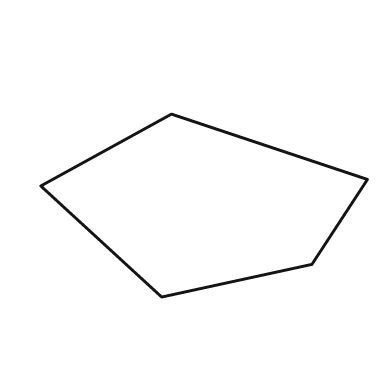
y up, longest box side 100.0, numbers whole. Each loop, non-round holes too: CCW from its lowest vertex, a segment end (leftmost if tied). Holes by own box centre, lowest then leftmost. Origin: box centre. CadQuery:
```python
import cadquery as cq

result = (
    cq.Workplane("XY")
    .moveTo(-13.0, -28.0)
    .lineTo(33.0, -18.0)
    .lineTo(50.0, 8.0)
    .lineTo(-10.0, 28.0)
    .lineTo(-50.0, 6.0)
    .close()
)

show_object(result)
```